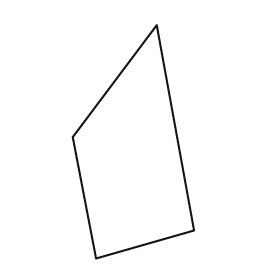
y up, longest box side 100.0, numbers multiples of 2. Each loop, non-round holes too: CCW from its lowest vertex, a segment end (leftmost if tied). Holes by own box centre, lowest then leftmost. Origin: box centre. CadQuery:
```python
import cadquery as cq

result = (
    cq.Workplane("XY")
    .moveTo(-16.0, -50.0)
    .lineTo(26.0, -38.0)
    .lineTo(10.0, 50.0)
    .lineTo(-26.0, 2.0)
    .close()
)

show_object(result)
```